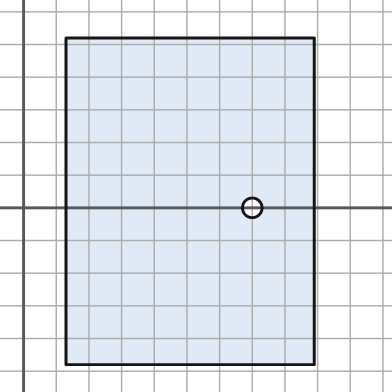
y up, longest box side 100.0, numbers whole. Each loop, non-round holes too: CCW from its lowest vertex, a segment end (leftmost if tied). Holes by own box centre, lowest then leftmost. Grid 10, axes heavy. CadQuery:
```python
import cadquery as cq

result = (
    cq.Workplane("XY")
    .moveTo(13.0, -48.0)
    .lineTo(89.0, -48.0)
    .lineTo(89.0, 52.0)
    .lineTo(13.0, 52.0)
    .close()
    .moveTo(70.0, 0.0)
    .circle(3.0)
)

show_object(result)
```